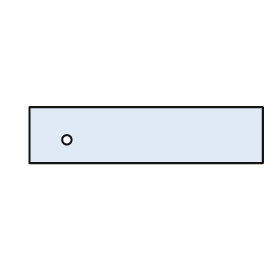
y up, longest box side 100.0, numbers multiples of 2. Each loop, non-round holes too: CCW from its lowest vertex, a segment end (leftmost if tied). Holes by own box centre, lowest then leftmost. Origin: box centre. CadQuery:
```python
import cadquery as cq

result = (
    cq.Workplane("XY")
    .moveTo(-50.0, -12.0)
    .lineTo(50.0, -12.0)
    .lineTo(50.0, 12.0)
    .lineTo(-50.0, 12.0)
    .close()
    .moveTo(-34.0, -2.0)
    .circle(2.0)
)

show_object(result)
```